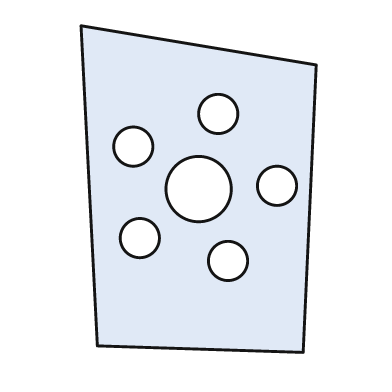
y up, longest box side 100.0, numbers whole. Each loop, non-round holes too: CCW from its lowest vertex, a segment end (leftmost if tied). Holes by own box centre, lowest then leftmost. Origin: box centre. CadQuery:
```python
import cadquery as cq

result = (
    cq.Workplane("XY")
    .moveTo(32.0, -50.0)
    .lineTo(36.0, 38.0)
    .lineTo(-36.0, 50.0)
    .lineTo(-31.0, -48.0)
    .close()
    .moveTo(9.0, -22.0)
    .circle(6.0)
    .moveTo(-18.0, -15.0)
    .circle(6.0)
    .moveTo(0.0, 0.0)
    .circle(10.0)
    .moveTo(24.0, 1.0)
    .circle(6.0)
    .moveTo(-20.0, 13.0)
    .circle(6.0)
    .moveTo(6.0, 23.0)
    .circle(6.0)
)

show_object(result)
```